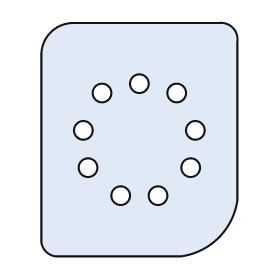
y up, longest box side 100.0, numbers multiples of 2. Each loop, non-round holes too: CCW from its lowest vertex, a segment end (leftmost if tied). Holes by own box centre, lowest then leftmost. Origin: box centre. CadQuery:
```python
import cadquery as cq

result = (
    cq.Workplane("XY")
    .moveTo(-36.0, -50.0)
    .lineTo(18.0, -50.0)
    .threePointArc((34.0, -42.0), (42.0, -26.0))
    .lineTo(42.0, 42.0)
    .threePointArc((40.0, 48.0), (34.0, 50.0))
    .lineTo(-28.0, 50.0)
    .threePointArc((-38.0, 46.0), (-42.0, 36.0))
    .lineTo(-42.0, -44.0)
    .threePointArc((-40.0, -48.0), (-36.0, -50.0))
    .close()
    .moveTo(-8.0, -24.0)
    .circle(4.0)
    .moveTo(8.0, -24.0)
    .circle(4.0)
    .moveTo(-22.0, -12.0)
    .circle(4.0)
    .moveTo(22.0, -12.0)
    .circle(4.0)
    .moveTo(-24.0, 4.0)
    .circle(4.0)
    .moveTo(24.0, 4.0)
    .circle(4.0)
    .moveTo(-16.0, 20.0)
    .circle(4.0)
    .moveTo(16.0, 20.0)
    .circle(4.0)
    .moveTo(0.0, 24.0)
    .circle(4.0)
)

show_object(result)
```